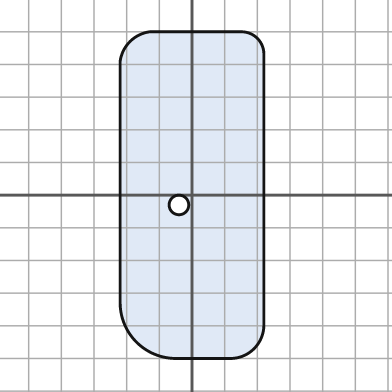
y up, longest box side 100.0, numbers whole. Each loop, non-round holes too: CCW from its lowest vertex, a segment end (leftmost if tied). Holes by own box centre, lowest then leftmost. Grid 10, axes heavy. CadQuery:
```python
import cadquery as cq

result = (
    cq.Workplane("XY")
    .moveTo(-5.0, -50.0)
    .lineTo(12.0, -50.0)
    .threePointArc((19.0, -47.0), (22.0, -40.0))
    .lineTo(22.0, 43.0)
    .threePointArc((20.0, 48.0), (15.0, 50.0))
    .lineTo(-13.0, 50.0)
    .threePointArc((-19.0, 47.0), (-22.0, 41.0))
    .lineTo(-22.0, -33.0)
    .threePointArc((-17.0, -45.0), (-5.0, -50.0))
    .close()
    .moveTo(-4.0, -3.0)
    .circle(3.0)
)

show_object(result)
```